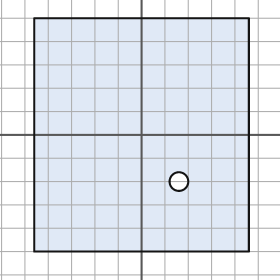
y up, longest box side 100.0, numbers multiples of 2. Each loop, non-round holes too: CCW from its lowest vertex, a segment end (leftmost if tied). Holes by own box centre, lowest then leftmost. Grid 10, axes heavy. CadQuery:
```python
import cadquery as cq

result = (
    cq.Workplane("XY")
    .moveTo(-46.0, -50.0)
    .lineTo(46.0, -50.0)
    .lineTo(46.0, 50.0)
    .lineTo(-46.0, 50.0)
    .close()
    .moveTo(16.0, -20.0)
    .circle(4.0)
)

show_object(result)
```